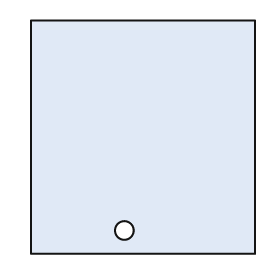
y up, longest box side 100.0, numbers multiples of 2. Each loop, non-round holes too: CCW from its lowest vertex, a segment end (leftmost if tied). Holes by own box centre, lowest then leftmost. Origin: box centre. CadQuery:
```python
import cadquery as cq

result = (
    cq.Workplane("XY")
    .moveTo(-48.0, -50.0)
    .lineTo(48.0, -50.0)
    .lineTo(48.0, 50.0)
    .lineTo(-48.0, 50.0)
    .close()
    .moveTo(-8.0, -40.0)
    .circle(4.0)
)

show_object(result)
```